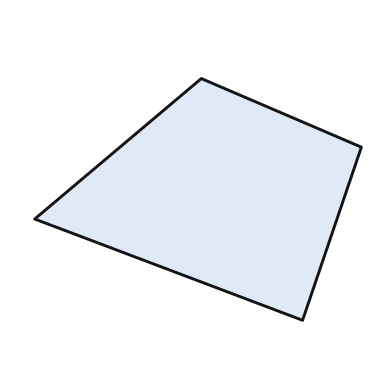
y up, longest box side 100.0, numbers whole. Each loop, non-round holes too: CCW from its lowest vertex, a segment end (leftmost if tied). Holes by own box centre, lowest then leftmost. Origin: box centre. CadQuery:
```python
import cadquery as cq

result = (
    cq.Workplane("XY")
    .moveTo(32.0, -37.0)
    .lineTo(50.0, 16.0)
    .lineTo(1.0, 37.0)
    .lineTo(-50.0, -6.0)
    .close()
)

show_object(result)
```